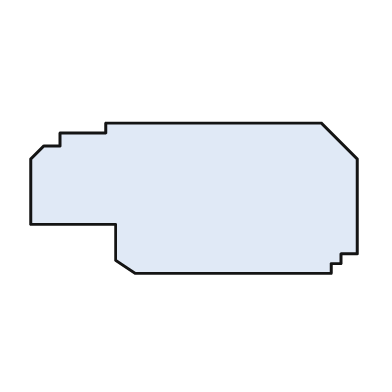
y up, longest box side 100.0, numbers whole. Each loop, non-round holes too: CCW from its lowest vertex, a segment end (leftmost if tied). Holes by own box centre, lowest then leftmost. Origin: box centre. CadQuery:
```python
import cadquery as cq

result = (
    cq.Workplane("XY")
    .moveTo(-18.0, -23.0)
    .lineTo(42.0, -23.0)
    .lineTo(42.0, -20.0)
    .lineTo(45.0, -20.0)
    .lineTo(45.0, -17.0)
    .lineTo(50.0, -17.0)
    .lineTo(50.0, 12.0)
    .lineTo(39.0, 23.0)
    .lineTo(-27.0, 23.0)
    .lineTo(-27.0, 20.0)
    .lineTo(-41.0, 20.0)
    .lineTo(-41.0, 16.0)
    .lineTo(-46.0, 16.0)
    .lineTo(-50.0, 12.0)
    .lineTo(-50.0, -8.0)
    .lineTo(-24.0, -8.0)
    .lineTo(-24.0, -19.0)
    .close()
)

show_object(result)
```